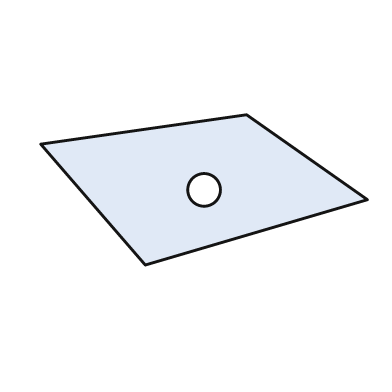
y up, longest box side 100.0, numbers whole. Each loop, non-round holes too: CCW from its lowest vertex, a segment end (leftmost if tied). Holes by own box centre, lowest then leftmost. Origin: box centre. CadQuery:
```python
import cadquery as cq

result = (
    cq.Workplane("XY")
    .moveTo(-18.0, -23.0)
    .lineTo(50.0, -3.0)
    .lineTo(13.0, 23.0)
    .lineTo(-50.0, 14.0)
    .close()
    .moveTo(0.0, 0.0)
    .circle(5.0)
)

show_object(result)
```